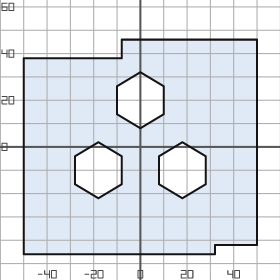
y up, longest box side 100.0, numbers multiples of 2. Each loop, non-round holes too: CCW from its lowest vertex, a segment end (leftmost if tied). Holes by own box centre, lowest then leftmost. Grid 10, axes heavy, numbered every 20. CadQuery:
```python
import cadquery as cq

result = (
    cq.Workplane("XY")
    .moveTo(-50.0, -46.0)
    .lineTo(32.0, -46.0)
    .lineTo(32.0, -42.0)
    .lineTo(50.0, -42.0)
    .lineTo(50.0, 46.0)
    .lineTo(-8.0, 46.0)
    .lineTo(-8.0, 38.0)
    .lineTo(-50.0, 38.0)
    .close()
    .moveTo(-18.0, -22.0)
    .lineTo(-8.0, -16.0)
    .lineTo(-8.0, -4.0)
    .lineTo(-18.0, 2.0)
    .lineTo(-28.0, -4.0)
    .lineTo(-28.0, -16.0)
    .close()
    .moveTo(18.0, -22.0)
    .lineTo(28.0, -16.0)
    .lineTo(28.0, -4.0)
    .lineTo(18.0, 2.0)
    .lineTo(8.0, -4.0)
    .lineTo(8.0, -16.0)
    .close()
    .moveTo(0.0, 8.0)
    .lineTo(10.0, 14.0)
    .lineTo(10.0, 26.0)
    .lineTo(0.0, 32.0)
    .lineTo(-10.0, 26.0)
    .lineTo(-10.0, 14.0)
    .close()
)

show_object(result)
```